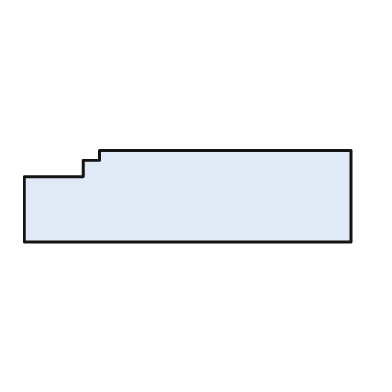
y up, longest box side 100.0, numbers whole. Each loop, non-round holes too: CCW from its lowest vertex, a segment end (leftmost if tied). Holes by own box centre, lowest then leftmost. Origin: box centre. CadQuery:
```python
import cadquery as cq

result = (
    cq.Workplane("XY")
    .moveTo(-50.0, -14.0)
    .lineTo(50.0, -14.0)
    .lineTo(50.0, 14.0)
    .lineTo(-27.0, 14.0)
    .lineTo(-27.0, 11.0)
    .lineTo(-32.0, 11.0)
    .lineTo(-32.0, 6.0)
    .lineTo(-50.0, 6.0)
    .close()
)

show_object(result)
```